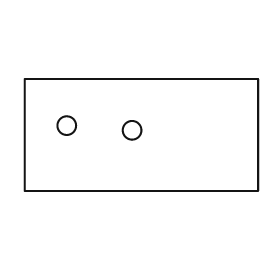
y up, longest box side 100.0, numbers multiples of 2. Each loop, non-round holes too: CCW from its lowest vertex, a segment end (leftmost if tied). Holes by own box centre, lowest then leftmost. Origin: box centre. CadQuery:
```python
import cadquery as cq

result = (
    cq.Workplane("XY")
    .moveTo(-50.0, -24.0)
    .lineTo(50.0, -24.0)
    .lineTo(50.0, 24.0)
    .lineTo(-50.0, 24.0)
    .close()
    .moveTo(-4.0, 2.0)
    .circle(4.0)
    .moveTo(-32.0, 4.0)
    .circle(4.0)
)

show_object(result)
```